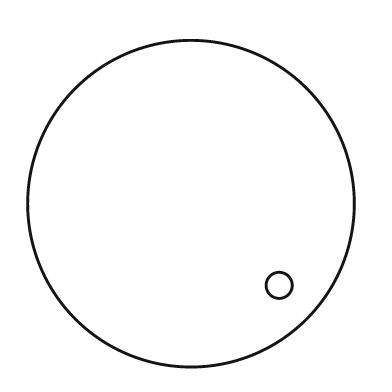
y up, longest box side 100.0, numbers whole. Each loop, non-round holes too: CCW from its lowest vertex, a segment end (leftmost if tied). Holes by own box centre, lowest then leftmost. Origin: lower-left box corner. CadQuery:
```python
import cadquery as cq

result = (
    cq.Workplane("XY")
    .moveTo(50.0, 50.0)
    .circle(50.0)
    .moveTo(77.0, 25.0)
    .circle(4.0)
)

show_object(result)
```